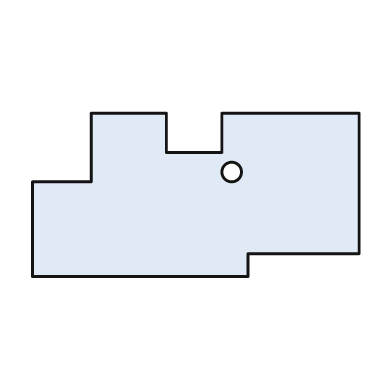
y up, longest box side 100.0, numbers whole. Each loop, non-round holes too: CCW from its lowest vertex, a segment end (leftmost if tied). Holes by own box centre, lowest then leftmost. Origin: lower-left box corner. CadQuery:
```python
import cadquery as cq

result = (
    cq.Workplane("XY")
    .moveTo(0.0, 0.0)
    .lineTo(66.0, 0.0)
    .lineTo(66.0, 7.0)
    .lineTo(100.0, 7.0)
    .lineTo(100.0, 50.0)
    .lineTo(58.0, 50.0)
    .lineTo(58.0, 38.0)
    .lineTo(41.0, 38.0)
    .lineTo(41.0, 50.0)
    .lineTo(18.0, 50.0)
    .lineTo(18.0, 29.0)
    .lineTo(0.0, 29.0)
    .close()
    .moveTo(61.0, 32.0)
    .circle(3.0)
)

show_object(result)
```